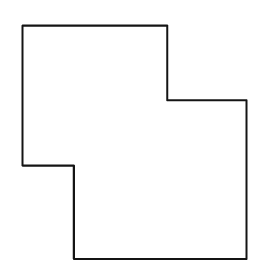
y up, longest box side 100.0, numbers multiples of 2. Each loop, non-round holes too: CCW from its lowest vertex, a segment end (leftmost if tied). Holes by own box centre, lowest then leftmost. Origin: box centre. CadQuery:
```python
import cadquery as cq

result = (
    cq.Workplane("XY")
    .moveTo(-26.0, -50.0)
    .lineTo(48.0, -50.0)
    .lineTo(48.0, 18.0)
    .lineTo(14.0, 18.0)
    .lineTo(14.0, 50.0)
    .lineTo(-48.0, 50.0)
    .lineTo(-48.0, -10.0)
    .lineTo(-26.0, -10.0)
    .close()
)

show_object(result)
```